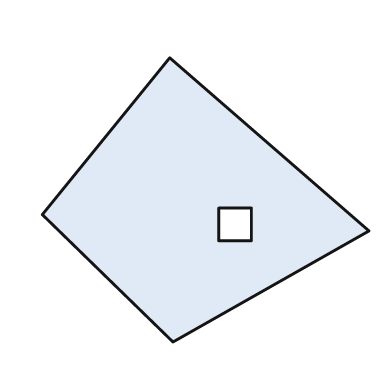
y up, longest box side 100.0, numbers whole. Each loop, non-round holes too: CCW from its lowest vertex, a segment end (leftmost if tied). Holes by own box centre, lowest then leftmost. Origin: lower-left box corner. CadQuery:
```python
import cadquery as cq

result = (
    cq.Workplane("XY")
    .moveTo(40.0, 0.0)
    .lineTo(100.0, 34.0)
    .lineTo(39.0, 87.0)
    .lineTo(0.0, 39.0)
    .close()
    .moveTo(54.0, 31.0)
    .lineTo(64.0, 31.0)
    .lineTo(64.0, 41.0)
    .lineTo(54.0, 41.0)
    .close()
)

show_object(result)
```